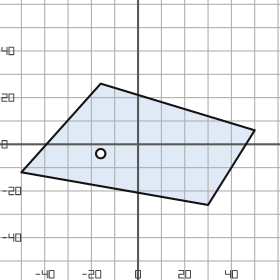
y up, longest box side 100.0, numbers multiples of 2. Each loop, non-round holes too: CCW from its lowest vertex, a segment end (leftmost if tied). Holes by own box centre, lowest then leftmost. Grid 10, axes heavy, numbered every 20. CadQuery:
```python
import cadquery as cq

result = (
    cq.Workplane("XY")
    .moveTo(30.0, -26.0)
    .lineTo(50.0, 6.0)
    .lineTo(-16.0, 26.0)
    .lineTo(-50.0, -12.0)
    .close()
    .moveTo(-16.0, -4.0)
    .circle(2.0)
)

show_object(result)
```